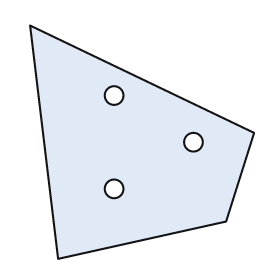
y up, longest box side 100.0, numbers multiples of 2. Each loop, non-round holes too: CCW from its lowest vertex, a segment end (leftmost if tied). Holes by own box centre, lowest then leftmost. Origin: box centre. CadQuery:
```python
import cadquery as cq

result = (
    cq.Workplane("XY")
    .moveTo(-36.0, -50.0)
    .lineTo(36.0, -34.0)
    .lineTo(48.0, 4.0)
    .lineTo(-48.0, 50.0)
    .close()
    .moveTo(-12.0, -20.0)
    .circle(4.0)
    .moveTo(22.0, 0.0)
    .circle(4.0)
    .moveTo(-12.0, 20.0)
    .circle(4.0)
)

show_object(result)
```